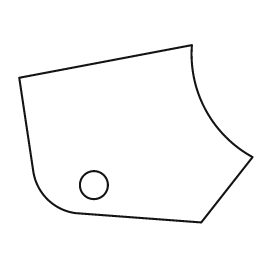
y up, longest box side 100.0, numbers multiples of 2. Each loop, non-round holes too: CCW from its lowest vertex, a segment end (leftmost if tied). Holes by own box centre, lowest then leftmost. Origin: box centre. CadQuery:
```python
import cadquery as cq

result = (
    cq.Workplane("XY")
    .moveTo(28.0, -38.0)
    .lineTo(50.0, -10.0)
    .threePointArc((30.0, 10.0), (24.0, 38.0))
    .lineTo(-50.0, 24.0)
    .lineTo(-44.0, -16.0)
    .threePointArc((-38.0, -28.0), (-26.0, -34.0))
    .close()
    .moveTo(-18.0, -22.0)
    .circle(6.0)
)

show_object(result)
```